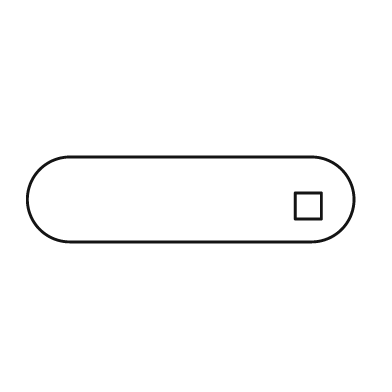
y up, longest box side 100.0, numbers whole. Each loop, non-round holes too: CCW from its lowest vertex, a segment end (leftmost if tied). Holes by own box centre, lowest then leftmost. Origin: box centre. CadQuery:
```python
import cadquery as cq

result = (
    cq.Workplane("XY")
    .moveTo(-37.0, -13.0)
    .lineTo(37.0, -13.0)
    .threePointArc((50.0, 0.0), (37.0, 13.0))
    .lineTo(-37.0, 13.0)
    .threePointArc((-50.0, 0.0), (-37.0, -13.0))
    .close()
    .moveTo(32.0, -6.0)
    .lineTo(40.0, -6.0)
    .lineTo(40.0, 2.0)
    .lineTo(32.0, 2.0)
    .close()
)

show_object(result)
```